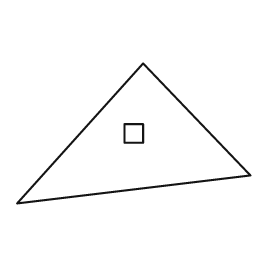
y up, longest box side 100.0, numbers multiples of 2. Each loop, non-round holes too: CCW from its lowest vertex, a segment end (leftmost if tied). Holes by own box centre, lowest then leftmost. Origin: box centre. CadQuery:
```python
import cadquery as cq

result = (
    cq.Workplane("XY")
    .moveTo(-50.0, -30.0)
    .lineTo(50.0, -18.0)
    .lineTo(4.0, 30.0)
    .close()
    .moveTo(-4.0, -4.0)
    .lineTo(4.0, -4.0)
    .lineTo(4.0, 4.0)
    .lineTo(-4.0, 4.0)
    .close()
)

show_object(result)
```